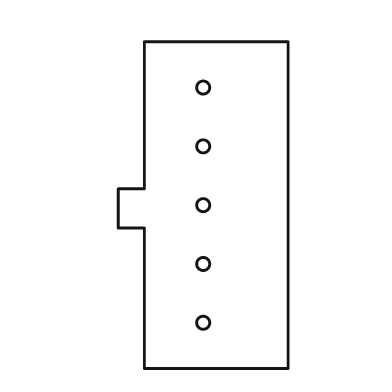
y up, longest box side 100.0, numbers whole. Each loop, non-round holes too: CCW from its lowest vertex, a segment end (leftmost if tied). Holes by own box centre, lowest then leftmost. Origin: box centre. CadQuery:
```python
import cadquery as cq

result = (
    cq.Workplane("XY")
    .moveTo(-18.0, -50.0)
    .lineTo(26.0, -50.0)
    .lineTo(26.0, 50.0)
    .lineTo(-18.0, 50.0)
    .lineTo(-18.0, 5.0)
    .lineTo(-26.0, 5.0)
    .lineTo(-26.0, -7.0)
    .lineTo(-18.0, -7.0)
    .close()
    .moveTo(0.0, -36.0)
    .circle(2.0)
    .moveTo(0.0, -18.0)
    .circle(2.0)
    .moveTo(0.0, 0.0)
    .circle(2.0)
    .moveTo(0.0, 18.0)
    .circle(2.0)
    .moveTo(0.0, 36.0)
    .circle(2.0)
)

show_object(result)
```